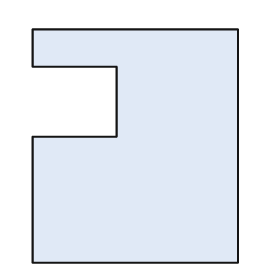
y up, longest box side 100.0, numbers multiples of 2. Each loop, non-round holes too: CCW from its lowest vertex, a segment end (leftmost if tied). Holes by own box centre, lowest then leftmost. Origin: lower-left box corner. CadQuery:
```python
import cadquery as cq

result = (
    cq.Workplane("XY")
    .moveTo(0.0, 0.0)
    .lineTo(88.0, 0.0)
    .lineTo(88.0, 100.0)
    .lineTo(0.0, 100.0)
    .lineTo(0.0, 84.0)
    .lineTo(36.0, 84.0)
    .lineTo(36.0, 54.0)
    .lineTo(0.0, 54.0)
    .close()
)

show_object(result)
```